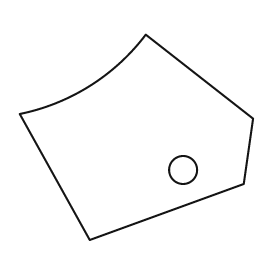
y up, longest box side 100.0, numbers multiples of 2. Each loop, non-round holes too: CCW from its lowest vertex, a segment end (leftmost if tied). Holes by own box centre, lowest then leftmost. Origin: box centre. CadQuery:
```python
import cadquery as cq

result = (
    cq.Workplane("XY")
    .moveTo(-20.0, -44.0)
    .lineTo(46.0, -20.0)
    .lineTo(50.0, 8.0)
    .lineTo(4.0, 44.0)
    .threePointArc((-20.0, 22.0), (-50.0, 10.0))
    .close()
    .moveTo(20.0, -14.0)
    .circle(6.0)
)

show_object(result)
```